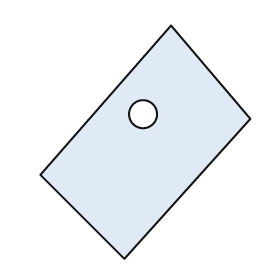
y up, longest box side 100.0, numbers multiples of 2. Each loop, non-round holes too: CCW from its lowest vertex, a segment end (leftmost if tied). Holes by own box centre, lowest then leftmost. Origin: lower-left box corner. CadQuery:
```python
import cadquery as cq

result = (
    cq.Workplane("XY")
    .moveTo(36.0, 0.0)
    .lineTo(90.0, 60.0)
    .lineTo(56.0, 100.0)
    .lineTo(0.0, 36.0)
    .close()
    .moveTo(44.0, 62.0)
    .circle(6.0)
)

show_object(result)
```